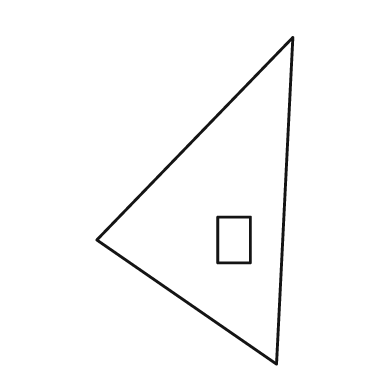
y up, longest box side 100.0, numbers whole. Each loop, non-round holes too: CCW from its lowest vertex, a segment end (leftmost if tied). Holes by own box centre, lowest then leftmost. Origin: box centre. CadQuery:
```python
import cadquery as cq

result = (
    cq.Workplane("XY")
    .moveTo(25.0, -50.0)
    .lineTo(30.0, 50.0)
    .lineTo(-30.0, -12.0)
    .close()
    .moveTo(7.0, -19.0)
    .lineTo(17.0, -19.0)
    .lineTo(17.0, -5.0)
    .lineTo(7.0, -5.0)
    .close()
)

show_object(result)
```